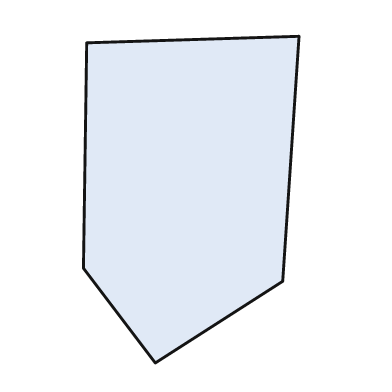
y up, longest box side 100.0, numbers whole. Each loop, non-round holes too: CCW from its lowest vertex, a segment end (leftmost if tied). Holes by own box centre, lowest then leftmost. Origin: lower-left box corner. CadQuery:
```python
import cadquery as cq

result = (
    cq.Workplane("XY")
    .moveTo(22.0, 0.0)
    .lineTo(61.0, 25.0)
    .lineTo(66.0, 100.0)
    .lineTo(1.0, 98.0)
    .lineTo(0.0, 29.0)
    .close()
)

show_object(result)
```